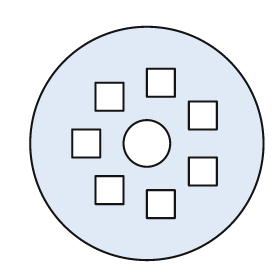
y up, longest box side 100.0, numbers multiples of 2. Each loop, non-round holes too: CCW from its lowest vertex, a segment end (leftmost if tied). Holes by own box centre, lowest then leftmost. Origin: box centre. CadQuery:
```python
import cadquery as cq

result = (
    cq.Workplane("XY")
    .moveTo(0.0, 0.0)
    .circle(50.0)
    .moveTo(0.0, -32.0)
    .lineTo(12.0, -32.0)
    .lineTo(12.0, -20.0)
    .lineTo(0.0, -20.0)
    .close()
    .moveTo(-22.0, -26.0)
    .lineTo(-10.0, -26.0)
    .lineTo(-10.0, -14.0)
    .lineTo(-22.0, -14.0)
    .close()
    .moveTo(18.0, -18.0)
    .lineTo(30.0, -18.0)
    .lineTo(30.0, -6.0)
    .lineTo(18.0, -6.0)
    .close()
    .moveTo(-32.0, -6.0)
    .lineTo(-20.0, -6.0)
    .lineTo(-20.0, 6.0)
    .lineTo(-32.0, 6.0)
    .close()
    .moveTo(0.0, 0.0)
    .circle(10.0)
    .moveTo(18.0, 6.0)
    .lineTo(30.0, 6.0)
    .lineTo(30.0, 18.0)
    .lineTo(18.0, 18.0)
    .close()
    .moveTo(-22.0, 14.0)
    .lineTo(-10.0, 14.0)
    .lineTo(-10.0, 26.0)
    .lineTo(-22.0, 26.0)
    .close()
    .moveTo(0.0, 20.0)
    .lineTo(12.0, 20.0)
    .lineTo(12.0, 32.0)
    .lineTo(0.0, 32.0)
    .close()
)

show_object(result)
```